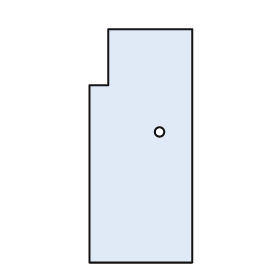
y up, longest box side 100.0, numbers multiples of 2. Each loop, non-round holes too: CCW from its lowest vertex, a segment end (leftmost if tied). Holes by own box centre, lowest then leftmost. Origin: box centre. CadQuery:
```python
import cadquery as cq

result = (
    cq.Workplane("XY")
    .moveTo(-22.0, -50.0)
    .lineTo(22.0, -50.0)
    .lineTo(22.0, 50.0)
    .lineTo(-14.0, 50.0)
    .lineTo(-14.0, 26.0)
    .lineTo(-22.0, 26.0)
    .close()
    .moveTo(8.0, 6.0)
    .circle(2.0)
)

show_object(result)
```